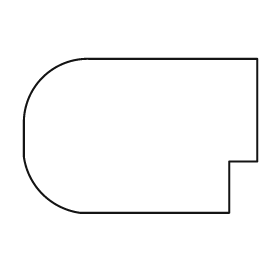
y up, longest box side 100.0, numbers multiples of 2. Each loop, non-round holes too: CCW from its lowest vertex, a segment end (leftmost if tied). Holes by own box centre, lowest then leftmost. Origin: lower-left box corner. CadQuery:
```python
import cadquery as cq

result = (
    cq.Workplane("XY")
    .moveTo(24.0, 0.0)
    .lineTo(88.0, 0.0)
    .lineTo(88.0, 22.0)
    .lineTo(100.0, 22.0)
    .lineTo(100.0, 66.0)
    .lineTo(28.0, 66.0)
    .threePointArc((8.0, 58.0), (0.0, 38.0))
    .lineTo(0.0, 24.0)
    .threePointArc((8.0, 8.0), (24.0, 0.0))
    .close()
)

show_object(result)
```